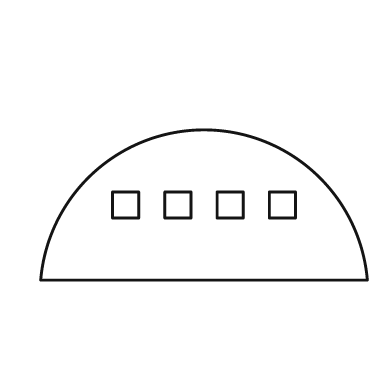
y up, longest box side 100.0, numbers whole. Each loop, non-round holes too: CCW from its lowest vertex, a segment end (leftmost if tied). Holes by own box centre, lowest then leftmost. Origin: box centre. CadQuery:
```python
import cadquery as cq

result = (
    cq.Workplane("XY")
    .moveTo(-50.0, -23.0)
    .lineTo(50.0, -23.0)
    .threePointArc((0.0, 23.0), (-50.0, -23.0))
    .close()
    .moveTo(-28.0, -4.0)
    .lineTo(-20.0, -4.0)
    .lineTo(-20.0, 4.0)
    .lineTo(-28.0, 4.0)
    .close()
    .moveTo(-12.0, -4.0)
    .lineTo(-4.0, -4.0)
    .lineTo(-4.0, 4.0)
    .lineTo(-12.0, 4.0)
    .close()
    .moveTo(4.0, -4.0)
    .lineTo(12.0, -4.0)
    .lineTo(12.0, 4.0)
    .lineTo(4.0, 4.0)
    .close()
    .moveTo(20.0, -4.0)
    .lineTo(28.0, -4.0)
    .lineTo(28.0, 4.0)
    .lineTo(20.0, 4.0)
    .close()
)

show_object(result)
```